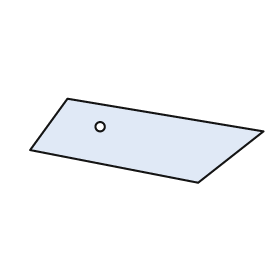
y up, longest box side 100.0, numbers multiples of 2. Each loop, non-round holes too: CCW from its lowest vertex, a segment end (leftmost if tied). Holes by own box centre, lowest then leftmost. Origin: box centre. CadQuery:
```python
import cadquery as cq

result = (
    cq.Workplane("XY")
    .moveTo(22.0, -18.0)
    .lineTo(50.0, 4.0)
    .lineTo(-34.0, 18.0)
    .lineTo(-50.0, -4.0)
    .close()
    .moveTo(-20.0, 6.0)
    .circle(2.0)
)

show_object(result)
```